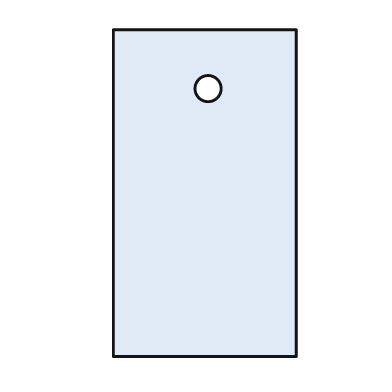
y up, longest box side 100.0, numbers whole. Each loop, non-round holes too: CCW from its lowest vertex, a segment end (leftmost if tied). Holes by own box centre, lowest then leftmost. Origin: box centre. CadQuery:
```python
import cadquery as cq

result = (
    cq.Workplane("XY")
    .moveTo(-28.0, -50.0)
    .lineTo(28.0, -50.0)
    .lineTo(28.0, 50.0)
    .lineTo(-28.0, 50.0)
    .close()
    .moveTo(1.0, 32.0)
    .circle(4.0)
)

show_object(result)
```